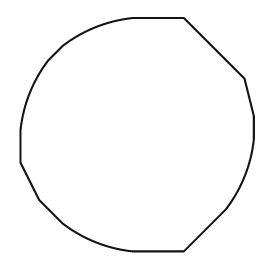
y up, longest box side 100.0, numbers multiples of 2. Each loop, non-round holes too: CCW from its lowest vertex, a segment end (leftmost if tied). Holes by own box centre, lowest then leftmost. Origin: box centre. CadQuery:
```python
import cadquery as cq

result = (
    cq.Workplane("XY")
    .moveTo(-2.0, -50.0)
    .lineTo(20.0, -50.0)
    .lineTo(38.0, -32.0)
    .threePointArc((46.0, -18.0), (50.0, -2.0))
    .lineTo(50.0, 8.0)
    .lineTo(46.0, 24.0)
    .lineTo(20.0, 50.0)
    .lineTo(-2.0, 50.0)
    .threePointArc((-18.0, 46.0), (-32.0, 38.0))
    .lineTo(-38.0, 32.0)
    .threePointArc((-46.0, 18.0), (-50.0, 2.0))
    .lineTo(-50.0, -12.0)
    .lineTo(-42.0, -28.0)
    .lineTo(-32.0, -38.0)
    .threePointArc((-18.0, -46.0), (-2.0, -50.0))
    .close()
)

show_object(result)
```